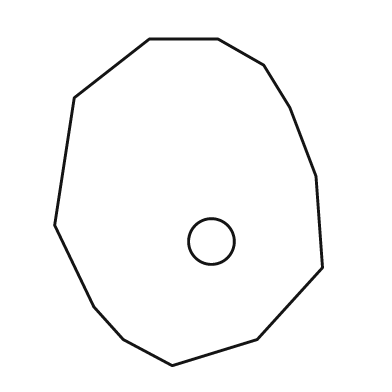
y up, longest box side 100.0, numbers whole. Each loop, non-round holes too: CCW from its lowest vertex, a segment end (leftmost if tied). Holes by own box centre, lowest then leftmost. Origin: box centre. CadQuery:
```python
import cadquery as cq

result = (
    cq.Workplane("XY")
    .moveTo(-5.0, -50.0)
    .lineTo(21.0, -42.0)
    .lineTo(41.0, -20.0)
    .lineTo(39.0, 8.0)
    .lineTo(31.0, 29.0)
    .lineTo(23.0, 42.0)
    .lineTo(9.0, 50.0)
    .lineTo(-12.0, 50.0)
    .lineTo(-35.0, 32.0)
    .lineTo(-41.0, -7.0)
    .lineTo(-29.0, -32.0)
    .lineTo(-20.0, -42.0)
    .close()
    .moveTo(7.0, -12.0)
    .circle(7.0)
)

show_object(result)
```